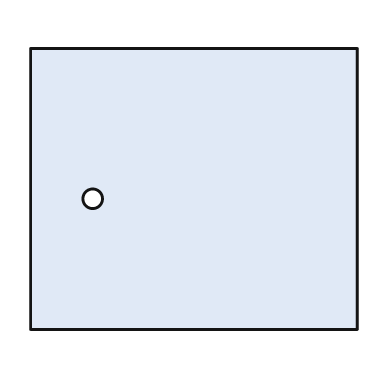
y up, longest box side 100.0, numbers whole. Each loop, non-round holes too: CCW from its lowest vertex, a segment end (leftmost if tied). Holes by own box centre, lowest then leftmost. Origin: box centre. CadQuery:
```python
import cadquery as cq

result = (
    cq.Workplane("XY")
    .moveTo(-50.0, -43.0)
    .lineTo(50.0, -43.0)
    .lineTo(50.0, 43.0)
    .lineTo(-50.0, 43.0)
    .close()
    .moveTo(-31.0, -3.0)
    .circle(3.0)
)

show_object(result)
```